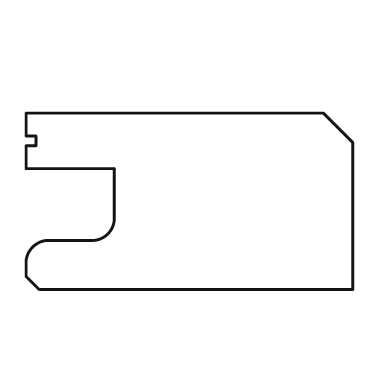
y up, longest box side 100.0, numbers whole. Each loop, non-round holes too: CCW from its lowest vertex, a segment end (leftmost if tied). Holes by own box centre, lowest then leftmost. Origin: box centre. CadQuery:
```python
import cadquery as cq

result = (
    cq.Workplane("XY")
    .moveTo(-46.0, -27.0)
    .lineTo(50.0, -27.0)
    .lineTo(50.0, 18.0)
    .lineTo(41.0, 27.0)
    .lineTo(-50.0, 27.0)
    .lineTo(-50.0, 20.0)
    .lineTo(-47.0, 20.0)
    .lineTo(-47.0, 17.0)
    .lineTo(-50.0, 17.0)
    .lineTo(-50.0, 10.0)
    .lineTo(-23.0, 10.0)
    .lineTo(-23.0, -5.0)
    .threePointArc((-25.0, -10.0), (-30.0, -12.0))
    .lineTo(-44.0, -12.0)
    .threePointArc((-48.0, -14.0), (-50.0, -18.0))
    .lineTo(-50.0, -23.0)
    .close()
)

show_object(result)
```